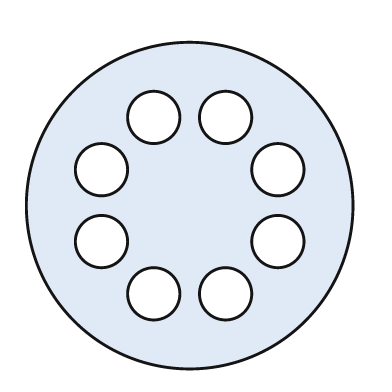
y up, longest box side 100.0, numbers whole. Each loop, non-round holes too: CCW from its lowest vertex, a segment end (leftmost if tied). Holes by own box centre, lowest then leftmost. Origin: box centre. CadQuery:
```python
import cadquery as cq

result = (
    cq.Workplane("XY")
    .moveTo(0.0, 0.0)
    .circle(50.0)
    .moveTo(-11.0, -27.0)
    .circle(8.0)
    .moveTo(11.0, -27.0)
    .circle(8.0)
    .moveTo(-27.0, -11.0)
    .circle(8.0)
    .moveTo(27.0, -11.0)
    .circle(8.0)
    .moveTo(-27.0, 11.0)
    .circle(8.0)
    .moveTo(27.0, 11.0)
    .circle(8.0)
    .moveTo(-11.0, 27.0)
    .circle(8.0)
    .moveTo(11.0, 27.0)
    .circle(8.0)
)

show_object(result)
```